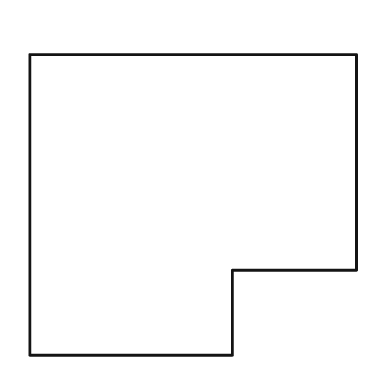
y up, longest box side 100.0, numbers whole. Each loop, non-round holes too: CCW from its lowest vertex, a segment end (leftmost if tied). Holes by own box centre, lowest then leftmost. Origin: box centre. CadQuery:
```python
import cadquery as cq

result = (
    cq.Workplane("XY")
    .moveTo(-50.0, -46.0)
    .lineTo(12.0, -46.0)
    .lineTo(12.0, -20.0)
    .lineTo(50.0, -20.0)
    .lineTo(50.0, 46.0)
    .lineTo(-50.0, 46.0)
    .close()
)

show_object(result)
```